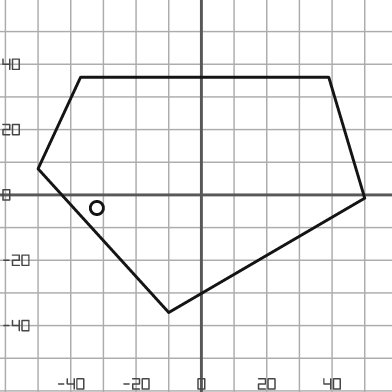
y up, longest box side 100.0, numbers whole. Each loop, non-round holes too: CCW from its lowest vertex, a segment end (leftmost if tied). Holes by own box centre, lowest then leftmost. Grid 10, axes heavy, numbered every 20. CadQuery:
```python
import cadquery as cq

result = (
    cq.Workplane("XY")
    .moveTo(-10.0, -36.0)
    .lineTo(50.0, -1.0)
    .lineTo(39.0, 36.0)
    .lineTo(-37.0, 36.0)
    .lineTo(-50.0, 8.0)
    .close()
    .moveTo(-32.0, -4.0)
    .circle(2.0)
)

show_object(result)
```